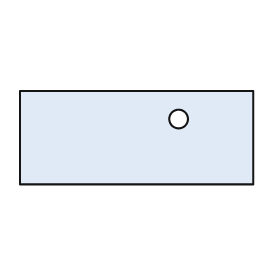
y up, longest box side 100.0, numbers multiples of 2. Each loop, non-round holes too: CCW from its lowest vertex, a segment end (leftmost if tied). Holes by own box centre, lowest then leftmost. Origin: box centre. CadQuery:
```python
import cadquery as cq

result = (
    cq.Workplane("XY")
    .moveTo(-50.0, -20.0)
    .lineTo(50.0, -20.0)
    .lineTo(50.0, 20.0)
    .lineTo(-50.0, 20.0)
    .close()
    .moveTo(18.0, 8.0)
    .circle(4.0)
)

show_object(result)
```